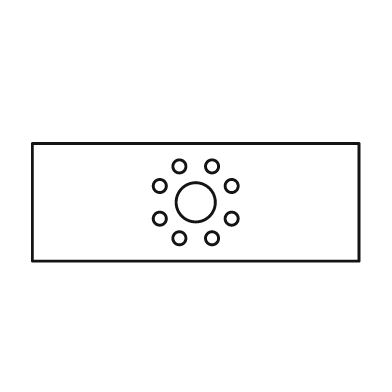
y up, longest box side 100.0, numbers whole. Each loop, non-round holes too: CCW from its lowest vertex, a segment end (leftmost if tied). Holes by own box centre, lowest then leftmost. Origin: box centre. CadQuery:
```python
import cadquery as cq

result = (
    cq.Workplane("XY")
    .moveTo(-50.0, -18.0)
    .lineTo(50.0, -18.0)
    .lineTo(50.0, 18.0)
    .lineTo(-50.0, 18.0)
    .close()
    .moveTo(-5.0, -11.0)
    .circle(2.0)
    .moveTo(5.0, -11.0)
    .circle(2.0)
    .moveTo(-11.0, -5.0)
    .circle(2.0)
    .moveTo(11.0, -5.0)
    .circle(2.0)
    .moveTo(0.0, 0.0)
    .circle(6.0)
    .moveTo(-11.0, 5.0)
    .circle(2.0)
    .moveTo(11.0, 5.0)
    .circle(2.0)
    .moveTo(-5.0, 11.0)
    .circle(2.0)
    .moveTo(5.0, 11.0)
    .circle(2.0)
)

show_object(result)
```